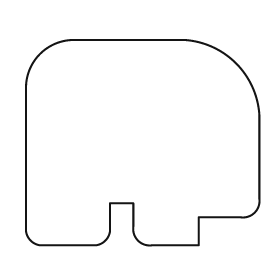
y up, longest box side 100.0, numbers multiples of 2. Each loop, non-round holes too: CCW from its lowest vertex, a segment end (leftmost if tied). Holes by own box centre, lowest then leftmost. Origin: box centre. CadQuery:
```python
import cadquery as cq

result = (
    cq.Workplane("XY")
    .moveTo(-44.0, -44.0)
    .lineTo(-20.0, -44.0)
    .threePointArc((-16.0, -42.0), (-14.0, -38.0))
    .lineTo(-14.0, -26.0)
    .lineTo(-4.0, -26.0)
    .lineTo(-4.0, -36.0)
    .threePointArc((-2.0, -42.0), (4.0, -44.0))
    .lineTo(24.0, -44.0)
    .lineTo(24.0, -32.0)
    .lineTo(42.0, -32.0)
    .threePointArc((48.0, -30.0), (50.0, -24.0))
    .lineTo(50.0, 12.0)
    .threePointArc((40.0, 34.0), (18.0, 44.0))
    .lineTo(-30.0, 44.0)
    .threePointArc((-44.0, 38.0), (-50.0, 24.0))
    .lineTo(-50.0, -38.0)
    .threePointArc((-48.0, -42.0), (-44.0, -44.0))
    .close()
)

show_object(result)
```